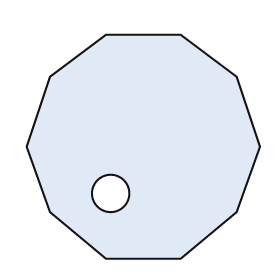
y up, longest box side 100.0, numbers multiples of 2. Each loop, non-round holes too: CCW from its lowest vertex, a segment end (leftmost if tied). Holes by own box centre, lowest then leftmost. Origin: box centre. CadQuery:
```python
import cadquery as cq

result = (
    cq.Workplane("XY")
    .moveTo(-16.0, -48.0)
    .lineTo(16.0, -48.0)
    .lineTo(40.0, -28.0)
    .lineTo(50.0, 0.0)
    .lineTo(40.0, 30.0)
    .lineTo(16.0, 48.0)
    .lineTo(-16.0, 48.0)
    .lineTo(-40.0, 30.0)
    .lineTo(-50.0, 0.0)
    .lineTo(-40.0, -28.0)
    .close()
    .moveTo(-14.0, -20.0)
    .circle(8.0)
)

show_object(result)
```